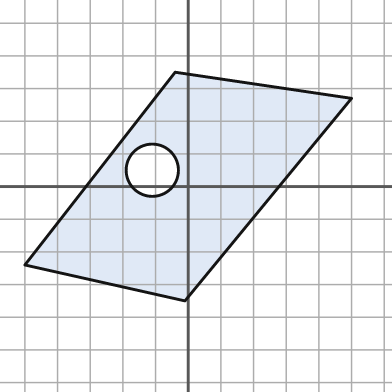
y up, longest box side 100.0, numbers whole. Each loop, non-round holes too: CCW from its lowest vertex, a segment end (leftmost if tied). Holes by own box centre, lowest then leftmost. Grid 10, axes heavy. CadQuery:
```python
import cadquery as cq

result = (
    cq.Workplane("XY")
    .moveTo(-1.0, -35.0)
    .lineTo(50.0, 27.0)
    .lineTo(-4.0, 35.0)
    .lineTo(-50.0, -24.0)
    .close()
    .moveTo(-11.0, 5.0)
    .circle(8.0)
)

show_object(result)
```